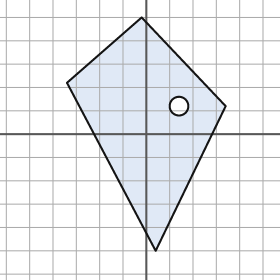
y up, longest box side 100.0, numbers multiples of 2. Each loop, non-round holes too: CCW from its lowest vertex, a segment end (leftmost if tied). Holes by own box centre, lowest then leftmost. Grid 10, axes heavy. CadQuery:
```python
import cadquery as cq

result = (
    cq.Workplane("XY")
    .moveTo(4.0, -50.0)
    .lineTo(34.0, 12.0)
    .lineTo(-2.0, 50.0)
    .lineTo(-34.0, 22.0)
    .close()
    .moveTo(14.0, 12.0)
    .circle(4.0)
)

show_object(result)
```